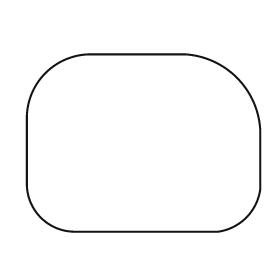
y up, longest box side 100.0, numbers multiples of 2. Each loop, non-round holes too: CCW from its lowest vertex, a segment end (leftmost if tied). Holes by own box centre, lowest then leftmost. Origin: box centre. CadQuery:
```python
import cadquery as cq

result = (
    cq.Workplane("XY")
    .moveTo(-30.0, -38.0)
    .lineTo(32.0, -38.0)
    .threePointArc((44.0, -32.0), (50.0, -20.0))
    .lineTo(50.0, 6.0)
    .threePointArc((40.0, 28.0), (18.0, 38.0))
    .lineTo(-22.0, 38.0)
    .threePointArc((-42.0, 30.0), (-50.0, 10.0))
    .lineTo(-50.0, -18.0)
    .threePointArc((-44.0, -32.0), (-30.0, -38.0))
    .close()
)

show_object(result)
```